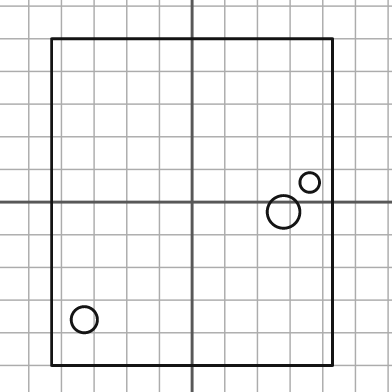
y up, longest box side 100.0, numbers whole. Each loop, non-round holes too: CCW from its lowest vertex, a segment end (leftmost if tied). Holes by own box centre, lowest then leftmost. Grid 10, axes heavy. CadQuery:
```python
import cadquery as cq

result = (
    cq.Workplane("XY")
    .moveTo(-43.0, -50.0)
    .lineTo(43.0, -50.0)
    .lineTo(43.0, 50.0)
    .lineTo(-43.0, 50.0)
    .close()
    .moveTo(-33.0, -36.0)
    .circle(4.0)
    .moveTo(28.0, -3.0)
    .circle(5.0)
    .moveTo(36.0, 6.0)
    .circle(3.0)
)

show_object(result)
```